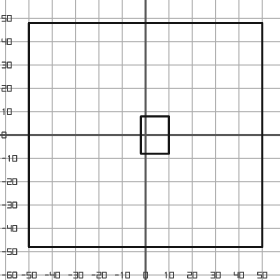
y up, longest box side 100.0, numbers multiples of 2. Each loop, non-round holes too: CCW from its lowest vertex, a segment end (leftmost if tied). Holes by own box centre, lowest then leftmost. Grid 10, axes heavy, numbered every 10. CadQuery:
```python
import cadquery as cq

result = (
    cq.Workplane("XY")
    .moveTo(-50.0, -48.0)
    .lineTo(50.0, -48.0)
    .lineTo(50.0, 48.0)
    .lineTo(-50.0, 48.0)
    .close()
    .moveTo(-2.0, -8.0)
    .lineTo(10.0, -8.0)
    .lineTo(10.0, 8.0)
    .lineTo(-2.0, 8.0)
    .close()
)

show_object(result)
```